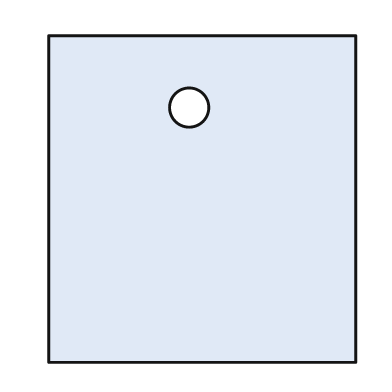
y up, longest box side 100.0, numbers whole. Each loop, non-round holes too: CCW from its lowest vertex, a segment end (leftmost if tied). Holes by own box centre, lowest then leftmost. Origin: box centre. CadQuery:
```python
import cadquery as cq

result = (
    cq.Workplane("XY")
    .moveTo(-47.0, -50.0)
    .lineTo(47.0, -50.0)
    .lineTo(47.0, 50.0)
    .lineTo(-47.0, 50.0)
    .close()
    .moveTo(-4.0, 28.0)
    .circle(6.0)
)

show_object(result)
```